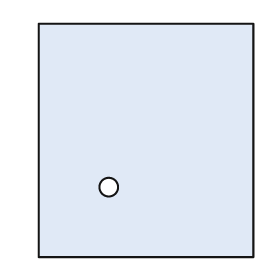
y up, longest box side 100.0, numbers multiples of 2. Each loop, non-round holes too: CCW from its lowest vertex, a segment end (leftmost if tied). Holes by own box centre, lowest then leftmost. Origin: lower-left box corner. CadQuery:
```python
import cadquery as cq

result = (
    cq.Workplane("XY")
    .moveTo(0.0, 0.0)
    .lineTo(92.0, 0.0)
    .lineTo(92.0, 100.0)
    .lineTo(0.0, 100.0)
    .close()
    .moveTo(30.0, 30.0)
    .circle(4.0)
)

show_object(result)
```